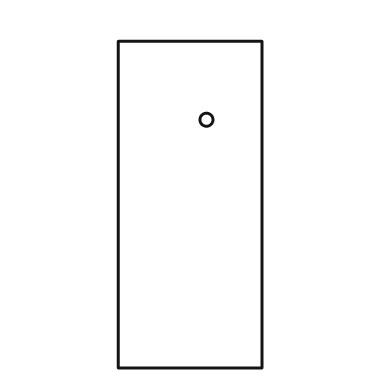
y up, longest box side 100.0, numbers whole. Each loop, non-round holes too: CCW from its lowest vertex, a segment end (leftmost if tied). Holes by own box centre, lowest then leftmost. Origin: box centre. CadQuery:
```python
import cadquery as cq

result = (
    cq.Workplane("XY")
    .moveTo(-22.0, -50.0)
    .lineTo(22.0, -50.0)
    .lineTo(22.0, 50.0)
    .lineTo(-22.0, 50.0)
    .close()
    .moveTo(5.0, 26.0)
    .circle(2.0)
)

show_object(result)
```